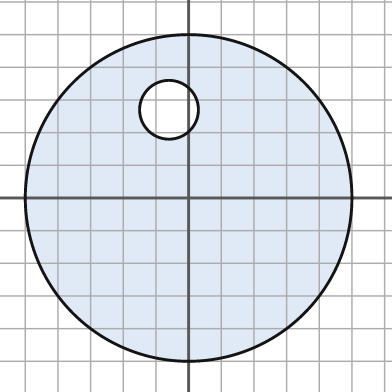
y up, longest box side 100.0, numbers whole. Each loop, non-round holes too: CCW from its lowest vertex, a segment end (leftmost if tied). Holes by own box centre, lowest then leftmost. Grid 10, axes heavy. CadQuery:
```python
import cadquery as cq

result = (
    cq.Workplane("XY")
    .moveTo(0.0, 0.0)
    .circle(50.0)
    .moveTo(-6.0, 27.0)
    .circle(9.0)
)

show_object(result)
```